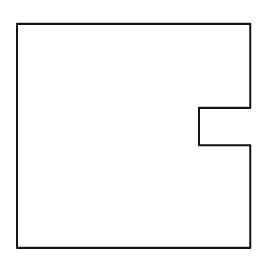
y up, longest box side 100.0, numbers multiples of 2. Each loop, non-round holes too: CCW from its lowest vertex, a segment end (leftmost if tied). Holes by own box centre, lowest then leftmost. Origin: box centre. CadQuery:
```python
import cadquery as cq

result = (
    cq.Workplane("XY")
    .moveTo(-50.0, -48.0)
    .lineTo(50.0, -48.0)
    .lineTo(50.0, -4.0)
    .lineTo(28.0, -4.0)
    .lineTo(28.0, 12.0)
    .lineTo(50.0, 12.0)
    .lineTo(50.0, 48.0)
    .lineTo(-50.0, 48.0)
    .close()
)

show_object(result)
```